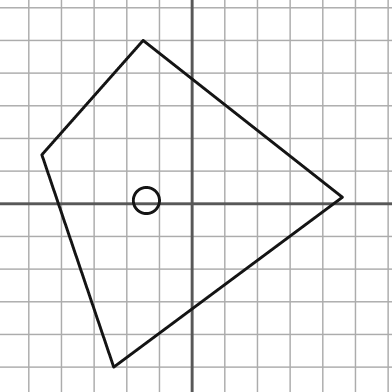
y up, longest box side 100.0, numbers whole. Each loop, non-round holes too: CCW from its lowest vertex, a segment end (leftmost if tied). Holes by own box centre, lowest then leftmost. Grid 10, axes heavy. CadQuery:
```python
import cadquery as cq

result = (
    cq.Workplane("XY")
    .moveTo(-24.0, -50.0)
    .lineTo(46.0, 2.0)
    .lineTo(-15.0, 50.0)
    .lineTo(-46.0, 15.0)
    .close()
    .moveTo(-14.0, 1.0)
    .circle(4.0)
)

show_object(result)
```